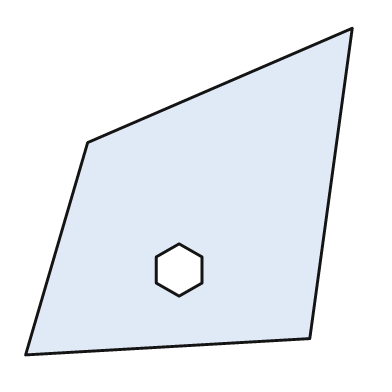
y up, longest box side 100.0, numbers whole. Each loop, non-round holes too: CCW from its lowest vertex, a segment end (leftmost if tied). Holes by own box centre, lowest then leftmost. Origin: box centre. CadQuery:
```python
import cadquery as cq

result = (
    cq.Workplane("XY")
    .moveTo(-50.0, -50.0)
    .lineTo(37.0, -45.0)
    .lineTo(50.0, 50.0)
    .lineTo(-31.0, 15.0)
    .close()
    .moveTo(-3.0, -32.0)
    .lineTo(4.0, -28.0)
    .lineTo(4.0, -20.0)
    .lineTo(-3.0, -16.0)
    .lineTo(-10.0, -20.0)
    .lineTo(-10.0, -28.0)
    .close()
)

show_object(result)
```